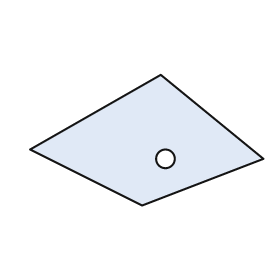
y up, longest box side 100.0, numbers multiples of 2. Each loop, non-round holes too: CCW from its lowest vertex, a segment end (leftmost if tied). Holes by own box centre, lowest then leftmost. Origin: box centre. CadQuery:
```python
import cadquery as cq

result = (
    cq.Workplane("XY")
    .moveTo(-2.0, -28.0)
    .lineTo(50.0, -8.0)
    .lineTo(6.0, 28.0)
    .lineTo(-50.0, -4.0)
    .close()
    .moveTo(8.0, -8.0)
    .circle(4.0)
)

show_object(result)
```